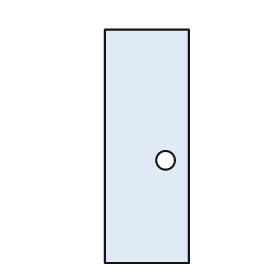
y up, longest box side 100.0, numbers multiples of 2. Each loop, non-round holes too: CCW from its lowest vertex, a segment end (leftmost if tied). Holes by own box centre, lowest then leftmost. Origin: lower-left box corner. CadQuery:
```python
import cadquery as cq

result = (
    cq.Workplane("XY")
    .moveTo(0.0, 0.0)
    .lineTo(36.0, 0.0)
    .lineTo(36.0, 100.0)
    .lineTo(0.0, 100.0)
    .close()
    .moveTo(26.0, 44.0)
    .circle(4.0)
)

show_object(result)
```